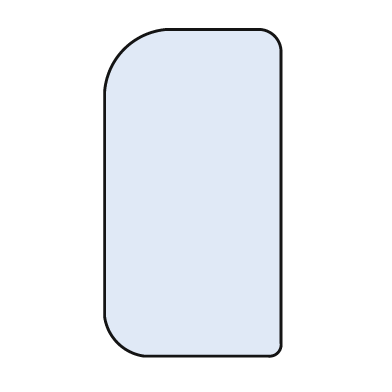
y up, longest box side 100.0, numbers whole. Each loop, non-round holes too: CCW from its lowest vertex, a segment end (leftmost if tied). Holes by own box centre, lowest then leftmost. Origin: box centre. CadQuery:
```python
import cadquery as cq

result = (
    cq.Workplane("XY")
    .moveTo(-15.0, -50.0)
    .lineTo(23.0, -50.0)
    .threePointArc((26.0, -49.0), (27.0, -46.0))
    .lineTo(27.0, 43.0)
    .threePointArc((25.0, 48.0), (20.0, 50.0))
    .lineTo(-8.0, 50.0)
    .threePointArc((-21.0, 44.0), (-27.0, 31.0))
    .lineTo(-27.0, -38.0)
    .threePointArc((-23.0, -46.0), (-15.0, -50.0))
    .close()
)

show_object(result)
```